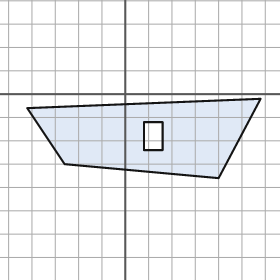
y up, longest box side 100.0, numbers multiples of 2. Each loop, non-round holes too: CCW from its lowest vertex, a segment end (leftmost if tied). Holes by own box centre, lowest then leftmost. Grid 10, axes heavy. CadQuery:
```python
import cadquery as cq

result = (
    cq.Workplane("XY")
    .moveTo(40.0, -36.0)
    .lineTo(58.0, -2.0)
    .lineTo(-42.0, -6.0)
    .lineTo(-26.0, -30.0)
    .close()
    .moveTo(8.0, -24.0)
    .lineTo(16.0, -24.0)
    .lineTo(16.0, -12.0)
    .lineTo(8.0, -12.0)
    .close()
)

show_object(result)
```